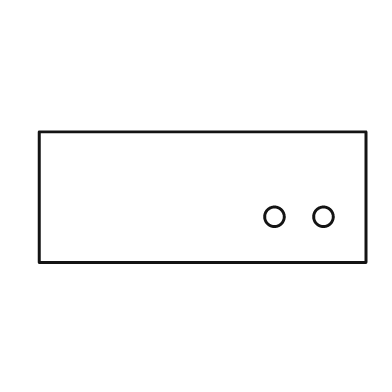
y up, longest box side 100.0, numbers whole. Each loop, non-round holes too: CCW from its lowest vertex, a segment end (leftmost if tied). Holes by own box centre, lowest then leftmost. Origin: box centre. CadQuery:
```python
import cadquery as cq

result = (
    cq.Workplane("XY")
    .moveTo(-50.0, -20.0)
    .lineTo(50.0, -20.0)
    .lineTo(50.0, 20.0)
    .lineTo(-50.0, 20.0)
    .close()
    .moveTo(22.0, -6.0)
    .circle(3.0)
    .moveTo(37.0, -6.0)
    .circle(3.0)
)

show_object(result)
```